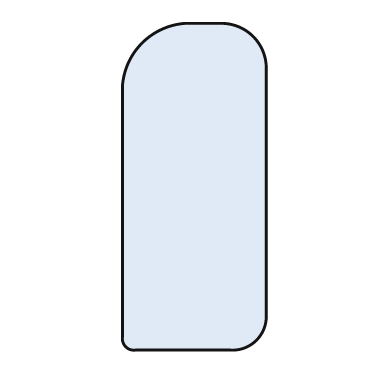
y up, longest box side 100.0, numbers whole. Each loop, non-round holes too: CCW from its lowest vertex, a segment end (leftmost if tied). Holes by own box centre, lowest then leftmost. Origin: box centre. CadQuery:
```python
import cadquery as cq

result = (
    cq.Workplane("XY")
    .moveTo(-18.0, -50.0)
    .lineTo(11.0, -50.0)
    .threePointArc((19.0, -47.0), (22.0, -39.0))
    .lineTo(22.0, 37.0)
    .threePointArc((18.0, 46.0), (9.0, 50.0))
    .lineTo(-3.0, 50.0)
    .threePointArc((-16.0, 44.0), (-22.0, 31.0))
    .lineTo(-22.0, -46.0)
    .threePointArc((-21.0, -49.0), (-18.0, -50.0))
    .close()
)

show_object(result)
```